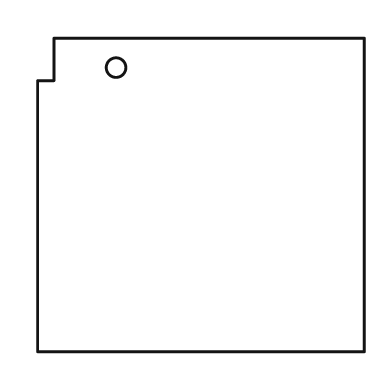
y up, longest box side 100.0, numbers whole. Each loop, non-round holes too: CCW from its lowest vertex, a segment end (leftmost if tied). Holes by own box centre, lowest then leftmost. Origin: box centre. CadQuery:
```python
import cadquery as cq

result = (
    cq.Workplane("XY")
    .moveTo(-50.0, -48.0)
    .lineTo(50.0, -48.0)
    .lineTo(50.0, 48.0)
    .lineTo(-45.0, 48.0)
    .lineTo(-45.0, 35.0)
    .lineTo(-50.0, 35.0)
    .close()
    .moveTo(-26.0, 39.0)
    .circle(3.0)
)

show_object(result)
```